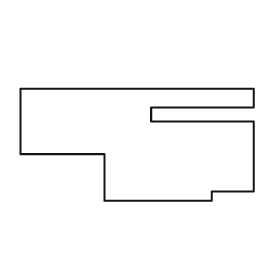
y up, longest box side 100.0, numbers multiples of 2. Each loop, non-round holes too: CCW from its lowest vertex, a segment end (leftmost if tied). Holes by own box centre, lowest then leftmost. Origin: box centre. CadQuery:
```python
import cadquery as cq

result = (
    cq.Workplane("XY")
    .moveTo(-14.0, -24.0)
    .lineTo(32.0, -24.0)
    .lineTo(32.0, -20.0)
    .lineTo(50.0, -20.0)
    .lineTo(50.0, 10.0)
    .lineTo(6.0, 10.0)
    .lineTo(6.0, 16.0)
    .lineTo(50.0, 16.0)
    .lineTo(50.0, 24.0)
    .lineTo(-50.0, 24.0)
    .lineTo(-50.0, -4.0)
    .lineTo(-14.0, -4.0)
    .close()
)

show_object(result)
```